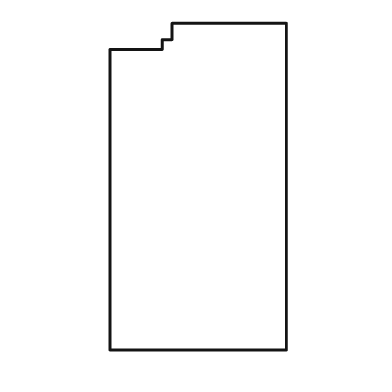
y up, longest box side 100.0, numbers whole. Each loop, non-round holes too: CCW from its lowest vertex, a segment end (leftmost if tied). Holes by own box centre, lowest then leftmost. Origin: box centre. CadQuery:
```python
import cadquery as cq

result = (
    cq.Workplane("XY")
    .moveTo(-27.0, -50.0)
    .lineTo(27.0, -50.0)
    .lineTo(27.0, 50.0)
    .lineTo(-8.0, 50.0)
    .lineTo(-8.0, 45.0)
    .lineTo(-11.0, 45.0)
    .lineTo(-11.0, 42.0)
    .lineTo(-27.0, 42.0)
    .close()
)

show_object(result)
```